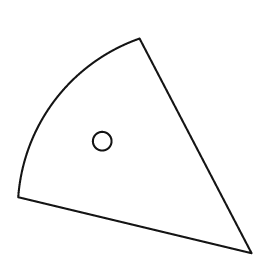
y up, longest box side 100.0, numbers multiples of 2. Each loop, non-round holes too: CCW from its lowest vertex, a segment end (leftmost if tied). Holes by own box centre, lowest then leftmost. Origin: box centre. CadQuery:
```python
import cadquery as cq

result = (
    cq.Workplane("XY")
    .moveTo(50.0, -46.0)
    .lineTo(2.0, 46.0)
    .threePointArc((-34.0, 20.0), (-50.0, -22.0))
    .close()
    .moveTo(-14.0, 2.0)
    .circle(4.0)
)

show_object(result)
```